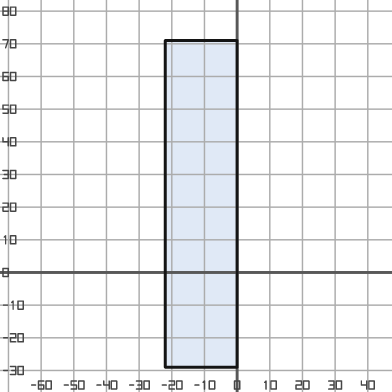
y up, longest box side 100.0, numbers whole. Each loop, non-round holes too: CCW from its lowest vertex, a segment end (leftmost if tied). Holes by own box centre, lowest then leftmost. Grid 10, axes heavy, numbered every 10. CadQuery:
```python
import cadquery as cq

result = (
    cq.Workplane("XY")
    .moveTo(-22.0, -29.0)
    .lineTo(0.0, -29.0)
    .lineTo(0.0, 71.0)
    .lineTo(-22.0, 71.0)
    .close()
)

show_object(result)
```